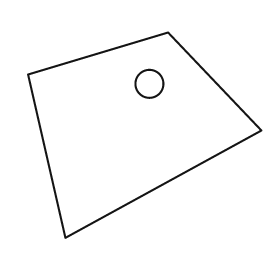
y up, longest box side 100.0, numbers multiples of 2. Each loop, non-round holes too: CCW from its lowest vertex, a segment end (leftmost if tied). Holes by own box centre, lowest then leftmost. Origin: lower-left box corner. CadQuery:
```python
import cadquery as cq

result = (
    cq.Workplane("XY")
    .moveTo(16.0, 0.0)
    .lineTo(100.0, 46.0)
    .lineTo(60.0, 88.0)
    .lineTo(0.0, 70.0)
    .close()
    .moveTo(52.0, 66.0)
    .circle(6.0)
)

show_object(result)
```